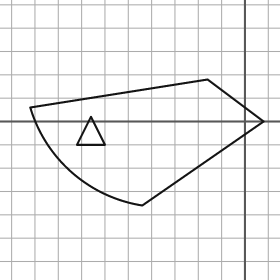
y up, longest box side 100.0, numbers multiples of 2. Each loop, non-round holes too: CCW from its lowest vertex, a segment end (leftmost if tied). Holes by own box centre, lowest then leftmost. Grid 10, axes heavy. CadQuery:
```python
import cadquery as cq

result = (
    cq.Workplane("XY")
    .moveTo(-44.0, -36.0)
    .lineTo(8.0, 0.0)
    .lineTo(-16.0, 18.0)
    .lineTo(-92.0, 6.0)
    .threePointArc((-74.0, -22.0), (-44.0, -36.0))
    .close()
    .moveTo(-72.0, -10.0)
    .lineTo(-60.0, -10.0)
    .lineTo(-66.0, 2.0)
    .close()
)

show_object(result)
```